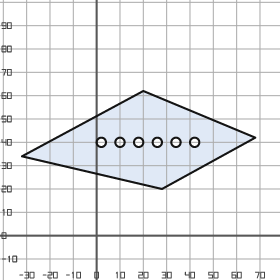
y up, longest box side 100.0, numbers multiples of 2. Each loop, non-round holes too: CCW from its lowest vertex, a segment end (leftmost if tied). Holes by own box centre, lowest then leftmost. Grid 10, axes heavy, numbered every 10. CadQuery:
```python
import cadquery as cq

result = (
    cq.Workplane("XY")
    .moveTo(28.0, 20.0)
    .lineTo(68.0, 42.0)
    .lineTo(20.0, 62.0)
    .lineTo(-32.0, 34.0)
    .close()
    .moveTo(2.0, 40.0)
    .circle(2.0)
    .moveTo(10.0, 40.0)
    .circle(2.0)
    .moveTo(18.0, 40.0)
    .circle(2.0)
    .moveTo(26.0, 40.0)
    .circle(2.0)
    .moveTo(34.0, 40.0)
    .circle(2.0)
    .moveTo(42.0, 40.0)
    .circle(2.0)
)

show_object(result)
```